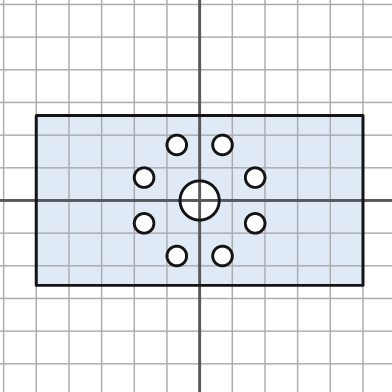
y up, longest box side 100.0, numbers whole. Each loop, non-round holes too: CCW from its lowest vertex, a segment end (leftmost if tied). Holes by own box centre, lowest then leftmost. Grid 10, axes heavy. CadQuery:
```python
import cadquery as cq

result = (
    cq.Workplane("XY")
    .moveTo(-50.0, -26.0)
    .lineTo(50.0, -26.0)
    .lineTo(50.0, 26.0)
    .lineTo(-50.0, 26.0)
    .close()
    .moveTo(-7.0, -17.0)
    .circle(3.0)
    .moveTo(7.0, -17.0)
    .circle(3.0)
    .moveTo(-17.0, -7.0)
    .circle(3.0)
    .moveTo(17.0, -7.0)
    .circle(3.0)
    .moveTo(0.0, 0.0)
    .circle(6.0)
    .moveTo(-17.0, 7.0)
    .circle(3.0)
    .moveTo(17.0, 7.0)
    .circle(3.0)
    .moveTo(-7.0, 17.0)
    .circle(3.0)
    .moveTo(7.0, 17.0)
    .circle(3.0)
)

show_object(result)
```